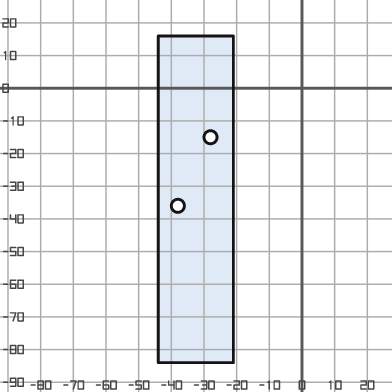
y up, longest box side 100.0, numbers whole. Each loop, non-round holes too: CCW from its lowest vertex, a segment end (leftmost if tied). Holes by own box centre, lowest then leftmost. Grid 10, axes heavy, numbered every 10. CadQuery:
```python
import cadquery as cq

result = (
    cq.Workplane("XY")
    .moveTo(-44.0, -84.0)
    .lineTo(-21.0, -84.0)
    .lineTo(-21.0, 16.0)
    .lineTo(-44.0, 16.0)
    .close()
    .moveTo(-38.0, -36.0)
    .circle(2.0)
    .moveTo(-28.0, -15.0)
    .circle(2.0)
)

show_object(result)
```